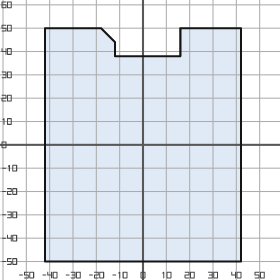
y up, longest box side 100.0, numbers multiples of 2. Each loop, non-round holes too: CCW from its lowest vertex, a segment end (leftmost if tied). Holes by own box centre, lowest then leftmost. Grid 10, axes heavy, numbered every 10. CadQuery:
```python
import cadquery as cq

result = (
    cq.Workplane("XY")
    .moveTo(-42.0, -50.0)
    .lineTo(42.0, -50.0)
    .lineTo(42.0, 50.0)
    .lineTo(16.0, 50.0)
    .lineTo(16.0, 38.0)
    .lineTo(-12.0, 38.0)
    .lineTo(-12.0, 44.0)
    .lineTo(-18.0, 50.0)
    .lineTo(-42.0, 50.0)
    .close()
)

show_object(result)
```